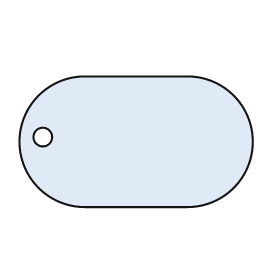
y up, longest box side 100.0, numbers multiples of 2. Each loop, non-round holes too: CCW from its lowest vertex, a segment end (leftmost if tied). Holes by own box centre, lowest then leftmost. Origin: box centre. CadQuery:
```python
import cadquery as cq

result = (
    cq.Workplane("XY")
    .moveTo(-22.0, -28.0)
    .lineTo(22.0, -28.0)
    .threePointArc((50.0, 0.0), (22.0, 28.0))
    .lineTo(-22.0, 28.0)
    .threePointArc((-50.0, 0.0), (-22.0, -28.0))
    .close()
    .moveTo(-40.0, 2.0)
    .circle(4.0)
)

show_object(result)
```